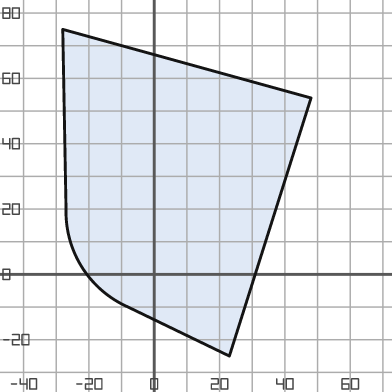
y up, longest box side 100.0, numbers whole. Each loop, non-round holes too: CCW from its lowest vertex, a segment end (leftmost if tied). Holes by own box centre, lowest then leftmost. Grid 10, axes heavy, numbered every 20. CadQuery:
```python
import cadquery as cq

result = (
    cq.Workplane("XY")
    .moveTo(23.0, -25.0)
    .lineTo(48.0, 54.0)
    .lineTo(-28.0, 75.0)
    .lineTo(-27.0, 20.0)
    .threePointArc((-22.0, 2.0), (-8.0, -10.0))
    .close()
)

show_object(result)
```